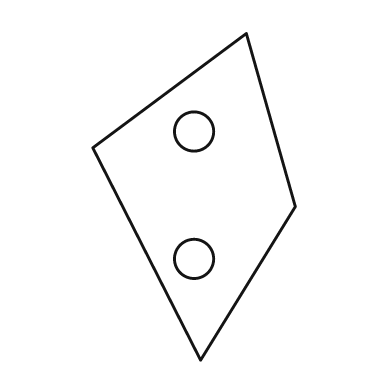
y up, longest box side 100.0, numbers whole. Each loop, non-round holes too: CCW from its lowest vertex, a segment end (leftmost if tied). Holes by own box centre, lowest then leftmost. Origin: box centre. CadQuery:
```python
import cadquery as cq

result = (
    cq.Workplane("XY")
    .moveTo(2.0, -50.0)
    .lineTo(31.0, -3.0)
    .lineTo(16.0, 50.0)
    .lineTo(-31.0, 15.0)
    .close()
    .moveTo(0.0, -19.0)
    .circle(6.0)
    .moveTo(0.0, 20.0)
    .circle(6.0)
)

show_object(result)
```